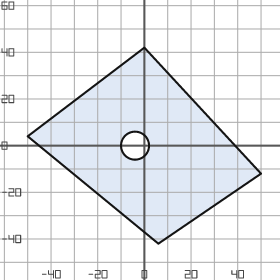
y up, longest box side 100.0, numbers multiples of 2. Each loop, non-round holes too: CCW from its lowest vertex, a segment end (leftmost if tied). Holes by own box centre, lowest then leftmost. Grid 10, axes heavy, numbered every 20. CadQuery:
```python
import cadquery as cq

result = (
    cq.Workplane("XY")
    .moveTo(6.0, -42.0)
    .lineTo(50.0, -12.0)
    .lineTo(0.0, 42.0)
    .lineTo(-50.0, 4.0)
    .close()
    .moveTo(-4.0, 0.0)
    .circle(6.0)
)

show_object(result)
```